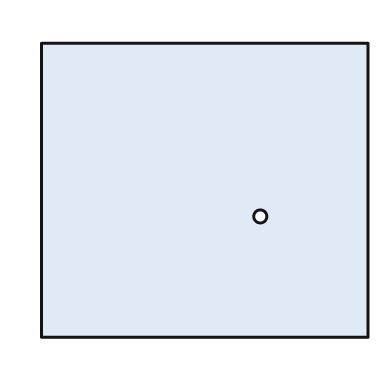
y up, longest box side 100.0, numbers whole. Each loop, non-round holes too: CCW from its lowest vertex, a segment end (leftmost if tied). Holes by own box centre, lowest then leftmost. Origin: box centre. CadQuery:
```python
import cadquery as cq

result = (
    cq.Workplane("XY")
    .moveTo(-50.0, -45.0)
    .lineTo(50.0, -45.0)
    .lineTo(50.0, 45.0)
    .lineTo(-50.0, 45.0)
    .close()
    .moveTo(17.0, -8.0)
    .circle(2.0)
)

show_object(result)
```